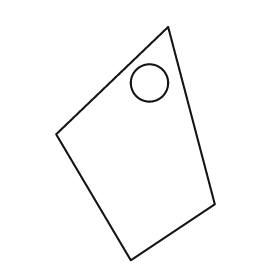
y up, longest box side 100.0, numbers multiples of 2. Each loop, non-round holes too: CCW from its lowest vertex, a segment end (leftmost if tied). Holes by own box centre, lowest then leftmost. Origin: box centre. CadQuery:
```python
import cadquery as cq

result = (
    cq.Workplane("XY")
    .moveTo(-2.0, -50.0)
    .lineTo(34.0, -26.0)
    .lineTo(14.0, 50.0)
    .lineTo(-34.0, 4.0)
    .close()
    .moveTo(6.0, 26.0)
    .circle(8.0)
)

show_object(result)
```